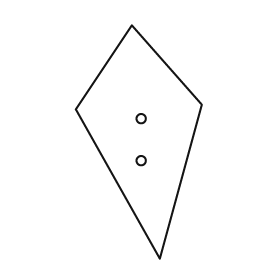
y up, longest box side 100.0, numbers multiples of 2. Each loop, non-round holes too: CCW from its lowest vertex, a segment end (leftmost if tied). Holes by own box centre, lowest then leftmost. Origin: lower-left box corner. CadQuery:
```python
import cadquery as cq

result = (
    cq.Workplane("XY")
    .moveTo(36.0, 0.0)
    .lineTo(54.0, 66.0)
    .lineTo(24.0, 100.0)
    .lineTo(0.0, 64.0)
    .close()
    .moveTo(28.0, 42.0)
    .circle(2.0)
    .moveTo(28.0, 60.0)
    .circle(2.0)
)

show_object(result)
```